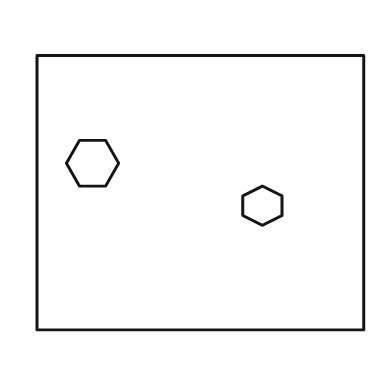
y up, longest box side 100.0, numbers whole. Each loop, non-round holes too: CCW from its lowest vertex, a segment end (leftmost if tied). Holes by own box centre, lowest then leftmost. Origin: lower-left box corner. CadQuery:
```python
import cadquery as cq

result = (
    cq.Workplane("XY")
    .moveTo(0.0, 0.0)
    .lineTo(100.0, 0.0)
    .lineTo(100.0, 84.0)
    .lineTo(0.0, 84.0)
    .close()
    .moveTo(69.0, 32.0)
    .lineTo(75.0, 35.0)
    .lineTo(75.0, 41.0)
    .lineTo(69.0, 44.0)
    .lineTo(63.0, 41.0)
    .lineTo(63.0, 35.0)
    .close()
    .moveTo(13.0, 44.0)
    .lineTo(21.0, 44.0)
    .lineTo(25.0, 51.0)
    .lineTo(21.0, 58.0)
    .lineTo(13.0, 58.0)
    .lineTo(9.0, 51.0)
    .close()
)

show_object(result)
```